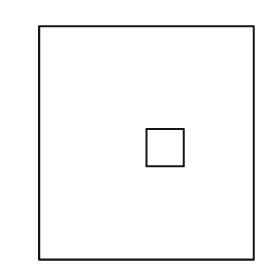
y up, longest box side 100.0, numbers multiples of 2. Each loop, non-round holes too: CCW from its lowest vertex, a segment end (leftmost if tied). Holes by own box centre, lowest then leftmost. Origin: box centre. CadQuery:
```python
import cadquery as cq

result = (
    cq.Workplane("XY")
    .moveTo(-46.0, -50.0)
    .lineTo(46.0, -50.0)
    .lineTo(46.0, 50.0)
    .lineTo(-46.0, 50.0)
    .close()
    .moveTo(0.0, -10.0)
    .lineTo(16.0, -10.0)
    .lineTo(16.0, 6.0)
    .lineTo(0.0, 6.0)
    .close()
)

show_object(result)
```